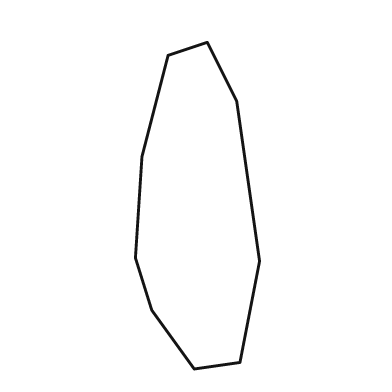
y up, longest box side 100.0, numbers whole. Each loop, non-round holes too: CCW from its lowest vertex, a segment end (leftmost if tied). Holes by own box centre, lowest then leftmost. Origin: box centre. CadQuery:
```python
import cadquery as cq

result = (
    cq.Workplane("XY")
    .moveTo(-1.0, -50.0)
    .lineTo(13.0, -48.0)
    .lineTo(19.0, -17.0)
    .lineTo(12.0, 32.0)
    .lineTo(3.0, 50.0)
    .lineTo(-9.0, 46.0)
    .lineTo(-17.0, 15.0)
    .lineTo(-19.0, -16.0)
    .lineTo(-14.0, -32.0)
    .close()
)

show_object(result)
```